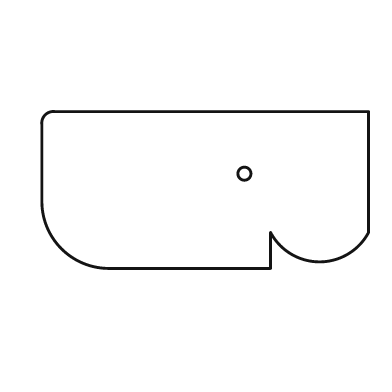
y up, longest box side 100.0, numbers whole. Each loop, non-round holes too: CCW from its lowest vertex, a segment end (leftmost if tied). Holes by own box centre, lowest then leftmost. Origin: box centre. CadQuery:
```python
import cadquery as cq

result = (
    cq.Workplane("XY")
    .moveTo(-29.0, -24.0)
    .lineTo(20.0, -24.0)
    .lineTo(20.0, -13.0)
    .threePointArc((35.0, -22.0), (50.0, -13.0))
    .lineTo(50.0, 24.0)
    .lineTo(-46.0, 24.0)
    .threePointArc((-49.0, 23.0), (-50.0, 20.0))
    .lineTo(-50.0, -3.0)
    .threePointArc((-44.0, -18.0), (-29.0, -24.0))
    .close()
    .moveTo(12.0, 5.0)
    .circle(2.0)
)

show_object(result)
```